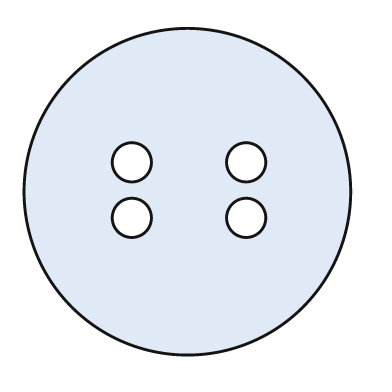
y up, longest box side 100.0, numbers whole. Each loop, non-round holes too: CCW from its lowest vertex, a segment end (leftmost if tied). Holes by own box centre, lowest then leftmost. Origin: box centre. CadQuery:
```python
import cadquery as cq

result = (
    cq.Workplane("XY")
    .moveTo(0.0, 0.0)
    .circle(50.0)
    .moveTo(-17.0, -8.0)
    .circle(6.0)
    .moveTo(18.0, -8.0)
    .circle(6.0)
    .moveTo(-17.0, 9.0)
    .circle(6.0)
    .moveTo(18.0, 9.0)
    .circle(6.0)
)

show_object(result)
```